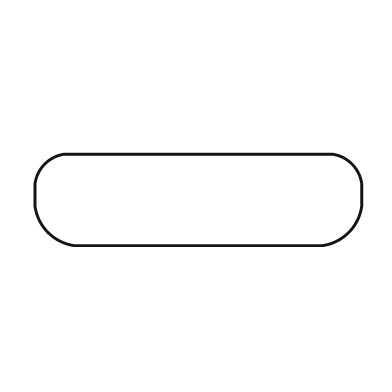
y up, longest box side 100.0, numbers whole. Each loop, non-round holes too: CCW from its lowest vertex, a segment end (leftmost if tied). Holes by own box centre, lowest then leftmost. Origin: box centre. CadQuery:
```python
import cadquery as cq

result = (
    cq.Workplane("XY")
    .moveTo(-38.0, -14.0)
    .lineTo(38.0, -14.0)
    .threePointArc((46.0, -10.0), (50.0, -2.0))
    .lineTo(50.0, 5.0)
    .threePointArc((47.0, 11.0), (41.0, 14.0))
    .lineTo(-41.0, 14.0)
    .threePointArc((-47.0, 11.0), (-50.0, 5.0))
    .lineTo(-50.0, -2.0)
    .threePointArc((-46.0, -10.0), (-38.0, -14.0))
    .close()
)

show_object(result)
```